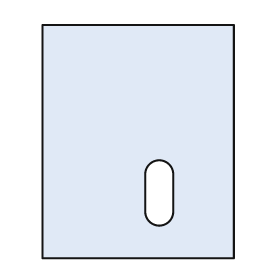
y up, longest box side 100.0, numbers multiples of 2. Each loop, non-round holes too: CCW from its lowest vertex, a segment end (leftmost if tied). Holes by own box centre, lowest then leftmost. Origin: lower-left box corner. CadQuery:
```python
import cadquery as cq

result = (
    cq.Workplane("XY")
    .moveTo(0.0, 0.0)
    .lineTo(82.0, 0.0)
    .lineTo(82.0, 100.0)
    .lineTo(0.0, 100.0)
    .close()
    .moveTo(44.0, 20.0)
    .threePointArc((50.0, 14.0), (56.0, 20.0))
    .lineTo(56.0, 36.0)
    .threePointArc((50.0, 42.0), (44.0, 36.0))
    .close()
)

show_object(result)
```